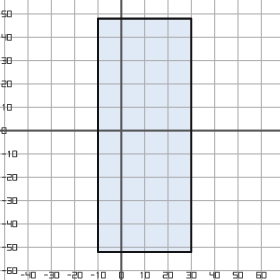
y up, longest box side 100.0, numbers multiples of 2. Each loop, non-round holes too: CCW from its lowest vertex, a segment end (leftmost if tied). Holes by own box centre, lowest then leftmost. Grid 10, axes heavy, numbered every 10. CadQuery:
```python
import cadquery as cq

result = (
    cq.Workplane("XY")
    .moveTo(-10.0, -52.0)
    .lineTo(30.0, -52.0)
    .lineTo(30.0, 48.0)
    .lineTo(-10.0, 48.0)
    .close()
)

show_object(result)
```